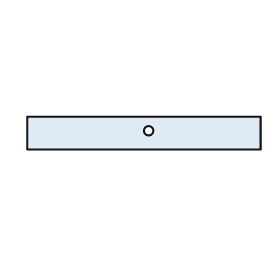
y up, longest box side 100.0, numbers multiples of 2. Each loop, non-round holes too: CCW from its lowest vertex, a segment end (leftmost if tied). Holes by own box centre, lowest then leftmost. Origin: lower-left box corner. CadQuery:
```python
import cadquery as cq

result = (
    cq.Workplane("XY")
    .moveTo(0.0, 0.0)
    .lineTo(100.0, 0.0)
    .lineTo(100.0, 14.0)
    .lineTo(0.0, 14.0)
    .close()
    .moveTo(52.0, 8.0)
    .circle(2.0)
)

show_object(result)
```